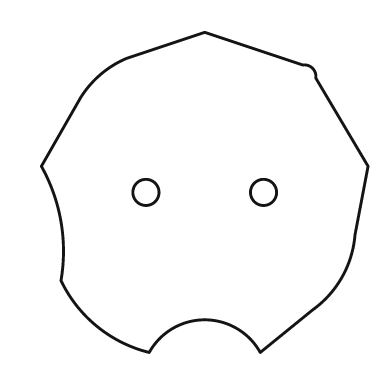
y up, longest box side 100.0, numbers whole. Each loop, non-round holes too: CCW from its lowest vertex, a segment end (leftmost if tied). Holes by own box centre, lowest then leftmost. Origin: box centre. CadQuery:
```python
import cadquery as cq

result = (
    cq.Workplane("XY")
    .moveTo(-17.0, -49.0)
    .threePointArc((0.0, -39.0), (17.0, -49.0))
    .lineTo(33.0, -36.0)
    .threePointArc((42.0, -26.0), (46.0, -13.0))
    .lineTo(50.0, 8.0)
    .lineTo(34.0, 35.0)
    .threePointArc((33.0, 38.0), (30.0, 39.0))
    .lineTo(0.0, 49.0)
    .lineTo(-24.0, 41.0)
    .threePointArc((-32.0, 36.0), (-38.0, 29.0))
    .lineTo(-50.0, 8.0)
    .threePointArc((-44.0, -9.0), (-44.0, -27.0))
    .threePointArc((-33.0, -41.0), (-17.0, -49.0))
    .close()
    .moveTo(-18.0, 0.0)
    .circle(4.0)
    .moveTo(18.0, 0.0)
    .circle(4.0)
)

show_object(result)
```